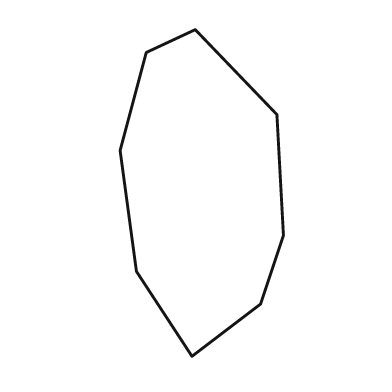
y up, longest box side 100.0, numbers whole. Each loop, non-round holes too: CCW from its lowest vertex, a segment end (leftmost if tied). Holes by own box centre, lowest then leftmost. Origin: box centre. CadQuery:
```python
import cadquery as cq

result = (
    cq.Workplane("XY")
    .moveTo(-3.0, -50.0)
    .lineTo(18.0, -34.0)
    .lineTo(25.0, -13.0)
    .lineTo(23.0, 24.0)
    .lineTo(-2.0, 50.0)
    .lineTo(-17.0, 43.0)
    .lineTo(-25.0, 13.0)
    .lineTo(-20.0, -24.0)
    .close()
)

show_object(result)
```